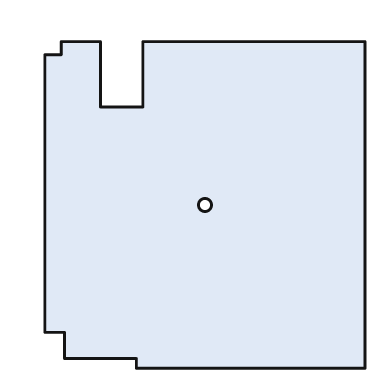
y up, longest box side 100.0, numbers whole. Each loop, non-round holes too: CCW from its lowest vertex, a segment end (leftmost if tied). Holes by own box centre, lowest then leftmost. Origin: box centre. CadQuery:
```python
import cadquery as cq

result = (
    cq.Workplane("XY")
    .moveTo(-21.0, -50.0)
    .lineTo(49.0, -50.0)
    .lineTo(49.0, 50.0)
    .lineTo(-19.0, 50.0)
    .lineTo(-19.0, 30.0)
    .lineTo(-32.0, 30.0)
    .lineTo(-32.0, 50.0)
    .lineTo(-44.0, 50.0)
    .lineTo(-44.0, 46.0)
    .lineTo(-49.0, 46.0)
    .lineTo(-49.0, -39.0)
    .lineTo(-43.0, -39.0)
    .lineTo(-43.0, -47.0)
    .lineTo(-21.0, -47.0)
    .close()
    .moveTo(0.0, 0.0)
    .circle(2.0)
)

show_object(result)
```